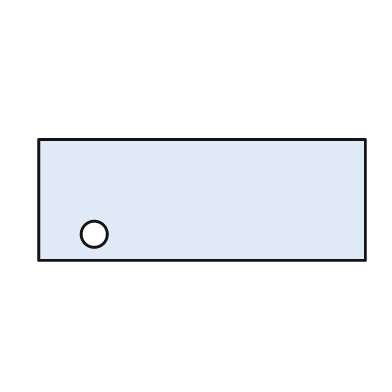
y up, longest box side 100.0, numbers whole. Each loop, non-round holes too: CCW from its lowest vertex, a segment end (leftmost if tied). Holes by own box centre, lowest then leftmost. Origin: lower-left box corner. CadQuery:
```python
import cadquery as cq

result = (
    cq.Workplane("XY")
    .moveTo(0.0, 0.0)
    .lineTo(100.0, 0.0)
    .lineTo(100.0, 37.0)
    .lineTo(0.0, 37.0)
    .close()
    .moveTo(17.0, 8.0)
    .circle(4.0)
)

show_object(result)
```